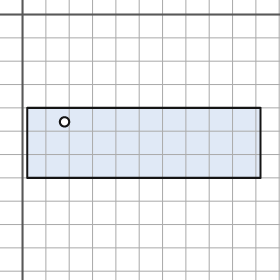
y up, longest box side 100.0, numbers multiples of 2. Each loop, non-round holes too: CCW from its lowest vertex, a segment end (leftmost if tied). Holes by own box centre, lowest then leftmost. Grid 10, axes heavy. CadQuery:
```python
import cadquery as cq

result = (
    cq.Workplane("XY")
    .moveTo(2.0, -70.0)
    .lineTo(102.0, -70.0)
    .lineTo(102.0, -40.0)
    .lineTo(2.0, -40.0)
    .close()
    .moveTo(18.0, -46.0)
    .circle(2.0)
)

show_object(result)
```